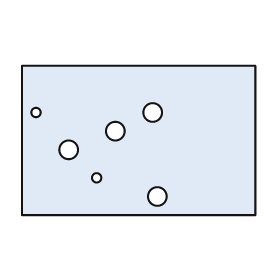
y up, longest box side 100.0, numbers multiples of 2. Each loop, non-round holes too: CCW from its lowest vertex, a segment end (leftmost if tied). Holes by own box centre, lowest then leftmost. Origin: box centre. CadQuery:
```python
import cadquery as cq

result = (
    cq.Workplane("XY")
    .moveTo(-50.0, -32.0)
    .lineTo(50.0, -32.0)
    .lineTo(50.0, 32.0)
    .lineTo(-50.0, 32.0)
    .close()
    .moveTo(8.0, -24.0)
    .circle(4.0)
    .moveTo(-18.0, -16.0)
    .circle(2.0)
    .moveTo(-30.0, -4.0)
    .circle(4.0)
    .moveTo(-10.0, 4.0)
    .circle(4.0)
    .moveTo(-44.0, 12.0)
    .circle(2.0)
    .moveTo(6.0, 12.0)
    .circle(4.0)
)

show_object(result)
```